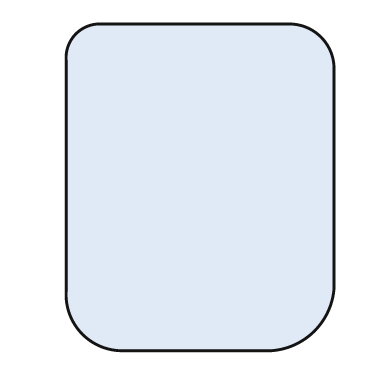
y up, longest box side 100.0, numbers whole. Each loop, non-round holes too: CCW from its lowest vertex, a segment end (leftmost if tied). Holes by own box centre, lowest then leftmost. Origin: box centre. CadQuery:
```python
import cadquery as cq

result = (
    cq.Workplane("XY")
    .moveTo(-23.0, -50.0)
    .lineTo(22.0, -50.0)
    .threePointArc((35.0, -44.0), (41.0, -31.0))
    .lineTo(41.0, 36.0)
    .threePointArc((37.0, 46.0), (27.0, 50.0))
    .lineTo(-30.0, 50.0)
    .threePointArc((-38.0, 47.0), (-41.0, 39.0))
    .lineTo(-41.0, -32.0)
    .threePointArc((-36.0, -45.0), (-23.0, -50.0))
    .close()
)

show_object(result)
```